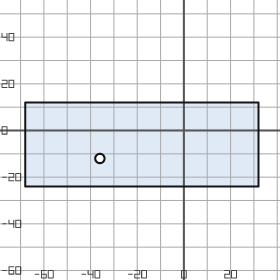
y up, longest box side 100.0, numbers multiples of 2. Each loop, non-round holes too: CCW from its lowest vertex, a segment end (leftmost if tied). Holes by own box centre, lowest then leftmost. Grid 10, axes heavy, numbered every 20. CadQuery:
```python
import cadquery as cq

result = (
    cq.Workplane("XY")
    .moveTo(-68.0, -24.0)
    .lineTo(32.0, -24.0)
    .lineTo(32.0, 12.0)
    .lineTo(-68.0, 12.0)
    .close()
    .moveTo(-36.0, -12.0)
    .circle(2.0)
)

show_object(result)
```